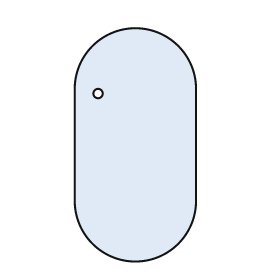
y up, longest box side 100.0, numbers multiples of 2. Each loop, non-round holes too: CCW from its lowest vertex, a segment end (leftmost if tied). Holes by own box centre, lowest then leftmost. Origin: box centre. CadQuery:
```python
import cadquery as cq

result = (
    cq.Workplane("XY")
    .moveTo(-26.0, -24.0)
    .threePointArc((0.0, -50.0), (26.0, -24.0))
    .lineTo(26.0, 24.0)
    .threePointArc((0.0, 50.0), (-26.0, 24.0))
    .close()
    .moveTo(-16.0, 22.0)
    .circle(2.0)
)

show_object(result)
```